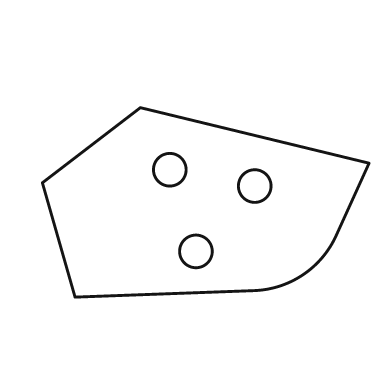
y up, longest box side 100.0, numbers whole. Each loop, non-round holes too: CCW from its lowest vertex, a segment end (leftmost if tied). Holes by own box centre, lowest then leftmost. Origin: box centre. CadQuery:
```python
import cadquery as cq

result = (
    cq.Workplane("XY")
    .moveTo(-40.0, -29.0)
    .lineTo(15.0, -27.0)
    .threePointArc((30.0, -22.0), (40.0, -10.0))
    .lineTo(50.0, 12.0)
    .lineTo(-20.0, 29.0)
    .lineTo(-50.0, 6.0)
    .close()
    .moveTo(-3.0, -15.0)
    .circle(5.0)
    .moveTo(15.0, 5.0)
    .circle(5.0)
    .moveTo(-11.0, 10.0)
    .circle(5.0)
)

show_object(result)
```